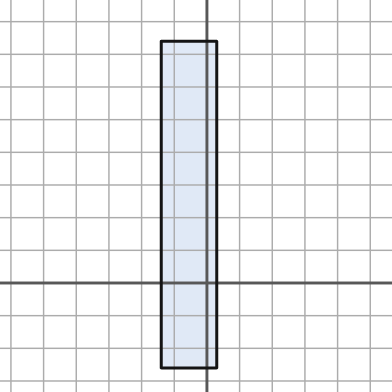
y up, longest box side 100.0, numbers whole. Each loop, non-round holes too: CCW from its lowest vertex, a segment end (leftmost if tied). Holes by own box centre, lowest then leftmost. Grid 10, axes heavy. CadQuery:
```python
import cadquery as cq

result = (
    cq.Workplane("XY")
    .moveTo(-14.0, -26.0)
    .lineTo(3.0, -26.0)
    .lineTo(3.0, 74.0)
    .lineTo(-14.0, 74.0)
    .close()
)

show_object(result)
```